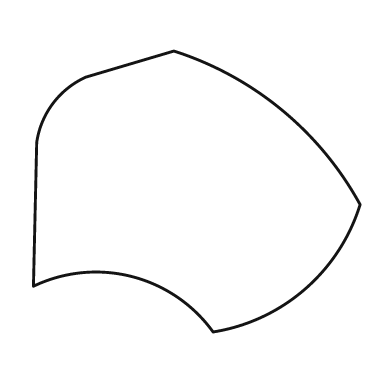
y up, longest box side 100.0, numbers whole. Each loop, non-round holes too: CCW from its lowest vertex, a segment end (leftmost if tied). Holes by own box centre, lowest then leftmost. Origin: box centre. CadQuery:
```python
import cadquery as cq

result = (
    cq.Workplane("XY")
    .moveTo(5.0, -43.0)
    .threePointArc((33.0, -30.0), (50.0, -4.0))
    .threePointArc((26.0, 25.0), (-7.0, 43.0))
    .lineTo(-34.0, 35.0)
    .threePointArc((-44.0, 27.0), (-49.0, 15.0))
    .lineTo(-50.0, -29.0)
    .threePointArc((-20.0, -26.0), (5.0, -43.0))
    .close()
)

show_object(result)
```